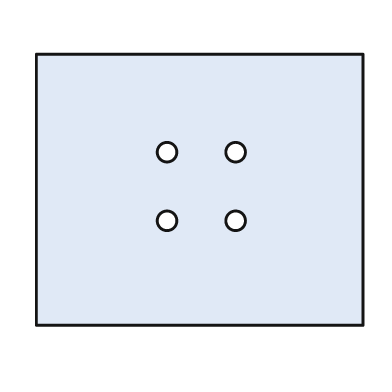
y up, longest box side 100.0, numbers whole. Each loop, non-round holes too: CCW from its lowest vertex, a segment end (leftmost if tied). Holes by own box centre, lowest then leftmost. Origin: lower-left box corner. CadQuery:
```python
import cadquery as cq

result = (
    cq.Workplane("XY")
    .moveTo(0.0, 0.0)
    .lineTo(100.0, 0.0)
    .lineTo(100.0, 83.0)
    .lineTo(0.0, 83.0)
    .close()
    .moveTo(40.0, 32.0)
    .circle(3.0)
    .moveTo(61.0, 32.0)
    .circle(3.0)
    .moveTo(40.0, 53.0)
    .circle(3.0)
    .moveTo(61.0, 53.0)
    .circle(3.0)
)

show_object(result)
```